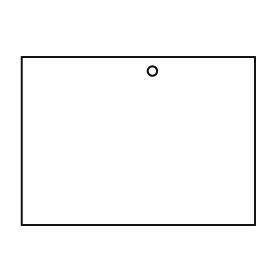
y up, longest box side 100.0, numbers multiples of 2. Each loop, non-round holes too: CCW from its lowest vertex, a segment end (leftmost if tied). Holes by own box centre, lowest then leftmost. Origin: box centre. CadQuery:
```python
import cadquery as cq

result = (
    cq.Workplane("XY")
    .moveTo(-50.0, -36.0)
    .lineTo(50.0, -36.0)
    .lineTo(50.0, 36.0)
    .lineTo(-50.0, 36.0)
    .close()
    .moveTo(6.0, 30.0)
    .circle(2.0)
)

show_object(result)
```